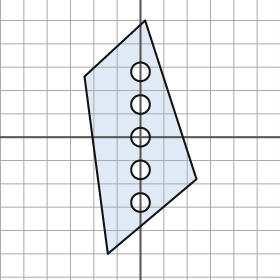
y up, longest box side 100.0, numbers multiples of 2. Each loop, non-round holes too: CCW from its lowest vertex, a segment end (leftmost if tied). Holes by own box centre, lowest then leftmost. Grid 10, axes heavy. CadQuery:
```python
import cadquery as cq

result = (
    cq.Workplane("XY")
    .moveTo(-14.0, -50.0)
    .lineTo(24.0, -18.0)
    .lineTo(2.0, 50.0)
    .lineTo(-24.0, 26.0)
    .close()
    .moveTo(0.0, -28.0)
    .circle(4.0)
    .moveTo(0.0, -14.0)
    .circle(4.0)
    .moveTo(0.0, 0.0)
    .circle(4.0)
    .moveTo(0.0, 14.0)
    .circle(4.0)
    .moveTo(0.0, 28.0)
    .circle(4.0)
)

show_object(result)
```